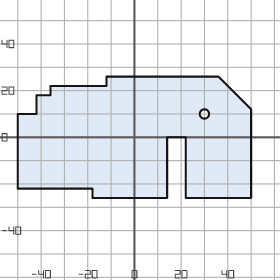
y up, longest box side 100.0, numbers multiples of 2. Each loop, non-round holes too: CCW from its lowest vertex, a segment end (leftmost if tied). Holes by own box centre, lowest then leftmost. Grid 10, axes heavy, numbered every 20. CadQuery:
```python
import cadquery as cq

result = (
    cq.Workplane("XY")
    .moveTo(-18.0, -26.0)
    .lineTo(14.0, -26.0)
    .lineTo(14.0, 0.0)
    .lineTo(22.0, 0.0)
    .lineTo(22.0, -26.0)
    .lineTo(50.0, -26.0)
    .lineTo(50.0, 12.0)
    .lineTo(36.0, 26.0)
    .lineTo(-12.0, 26.0)
    .lineTo(-12.0, 22.0)
    .lineTo(-36.0, 22.0)
    .lineTo(-36.0, 18.0)
    .lineTo(-42.0, 18.0)
    .lineTo(-42.0, 10.0)
    .lineTo(-50.0, 10.0)
    .lineTo(-50.0, -22.0)
    .lineTo(-18.0, -22.0)
    .close()
    .moveTo(30.0, 10.0)
    .circle(2.0)
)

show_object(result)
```